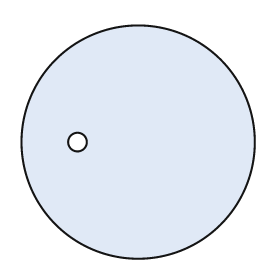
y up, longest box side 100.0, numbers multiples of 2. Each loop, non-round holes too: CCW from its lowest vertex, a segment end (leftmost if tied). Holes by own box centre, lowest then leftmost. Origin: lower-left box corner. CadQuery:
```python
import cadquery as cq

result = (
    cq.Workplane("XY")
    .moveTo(50.0, 50.0)
    .circle(50.0)
    .moveTo(24.0, 50.0)
    .circle(4.0)
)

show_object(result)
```